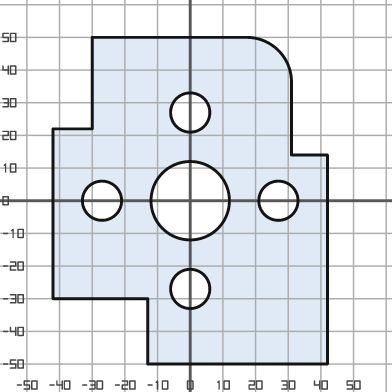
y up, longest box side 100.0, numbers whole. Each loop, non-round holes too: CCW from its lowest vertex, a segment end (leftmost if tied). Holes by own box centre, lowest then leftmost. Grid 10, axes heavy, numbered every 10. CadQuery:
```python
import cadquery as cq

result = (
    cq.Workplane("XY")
    .moveTo(-13.0, -50.0)
    .lineTo(42.0, -50.0)
    .lineTo(42.0, 14.0)
    .lineTo(31.0, 14.0)
    .lineTo(31.0, 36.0)
    .threePointArc((27.0, 46.0), (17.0, 50.0))
    .lineTo(-30.0, 50.0)
    .lineTo(-30.0, 22.0)
    .lineTo(-42.0, 22.0)
    .lineTo(-42.0, -30.0)
    .lineTo(-13.0, -30.0)
    .close()
    .moveTo(0.0, -27.0)
    .circle(6.0)
    .moveTo(-27.0, 0.0)
    .circle(6.0)
    .moveTo(0.0, 0.0)
    .circle(12.0)
    .moveTo(27.0, 0.0)
    .circle(6.0)
    .moveTo(0.0, 27.0)
    .circle(6.0)
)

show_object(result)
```